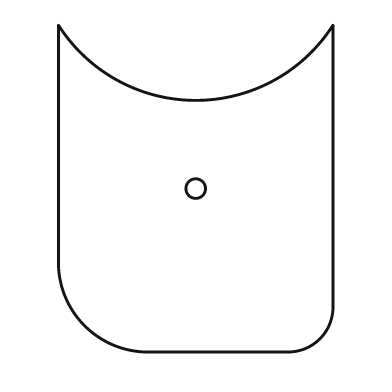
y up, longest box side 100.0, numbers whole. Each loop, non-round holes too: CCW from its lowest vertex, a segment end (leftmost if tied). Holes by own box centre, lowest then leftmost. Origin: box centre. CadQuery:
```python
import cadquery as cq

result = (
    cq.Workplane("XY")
    .moveTo(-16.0, -50.0)
    .lineTo(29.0, -50.0)
    .threePointArc((38.0, -46.0), (42.0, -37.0))
    .lineTo(42.0, 50.0)
    .threePointArc((0.0, 27.0), (-42.0, 50.0))
    .lineTo(-42.0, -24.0)
    .threePointArc((-34.0, -42.0), (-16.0, -50.0))
    .close()
    .moveTo(0.0, 0.0)
    .circle(3.0)
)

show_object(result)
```